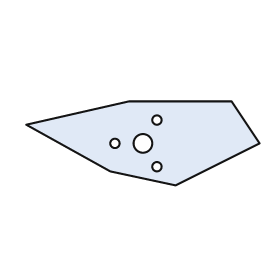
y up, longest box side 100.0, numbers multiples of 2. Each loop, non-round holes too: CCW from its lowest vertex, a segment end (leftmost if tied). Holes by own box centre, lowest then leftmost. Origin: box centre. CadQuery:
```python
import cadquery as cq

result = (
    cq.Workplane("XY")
    .moveTo(14.0, -18.0)
    .lineTo(50.0, 0.0)
    .lineTo(38.0, 18.0)
    .lineTo(-6.0, 18.0)
    .lineTo(-50.0, 8.0)
    .lineTo(-14.0, -12.0)
    .close()
    .moveTo(6.0, -10.0)
    .circle(2.0)
    .moveTo(-12.0, 0.0)
    .circle(2.0)
    .moveTo(0.0, 0.0)
    .circle(4.0)
    .moveTo(6.0, 10.0)
    .circle(2.0)
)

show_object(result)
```